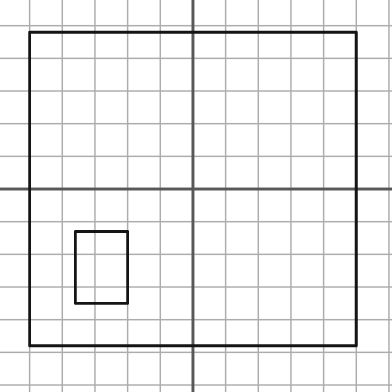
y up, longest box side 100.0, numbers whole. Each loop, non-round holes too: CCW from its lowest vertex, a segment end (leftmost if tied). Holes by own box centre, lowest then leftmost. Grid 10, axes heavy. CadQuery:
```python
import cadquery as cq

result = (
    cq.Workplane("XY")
    .moveTo(-50.0, -48.0)
    .lineTo(50.0, -48.0)
    .lineTo(50.0, 48.0)
    .lineTo(-50.0, 48.0)
    .close()
    .moveTo(-36.0, -35.0)
    .lineTo(-20.0, -35.0)
    .lineTo(-20.0, -13.0)
    .lineTo(-36.0, -13.0)
    .close()
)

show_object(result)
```